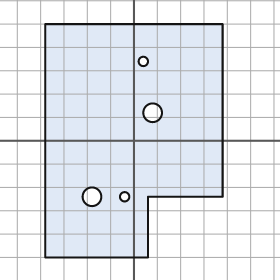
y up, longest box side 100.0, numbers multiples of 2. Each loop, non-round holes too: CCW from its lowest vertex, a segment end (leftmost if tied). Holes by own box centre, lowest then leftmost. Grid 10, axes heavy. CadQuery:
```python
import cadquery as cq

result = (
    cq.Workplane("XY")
    .moveTo(-38.0, -50.0)
    .lineTo(6.0, -50.0)
    .lineTo(6.0, -24.0)
    .lineTo(38.0, -24.0)
    .lineTo(38.0, 50.0)
    .lineTo(-38.0, 50.0)
    .close()
    .moveTo(-18.0, -24.0)
    .circle(4.0)
    .moveTo(-4.0, -24.0)
    .circle(2.0)
    .moveTo(8.0, 12.0)
    .circle(4.0)
    .moveTo(4.0, 34.0)
    .circle(2.0)
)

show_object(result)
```